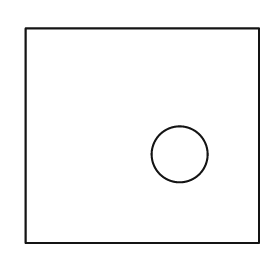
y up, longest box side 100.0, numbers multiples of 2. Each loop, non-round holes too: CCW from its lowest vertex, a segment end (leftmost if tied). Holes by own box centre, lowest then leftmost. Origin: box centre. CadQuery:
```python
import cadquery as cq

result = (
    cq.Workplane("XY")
    .moveTo(-50.0, -46.0)
    .lineTo(50.0, -46.0)
    .lineTo(50.0, 46.0)
    .lineTo(-50.0, 46.0)
    .close()
    .moveTo(16.0, -8.0)
    .circle(12.0)
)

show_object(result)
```